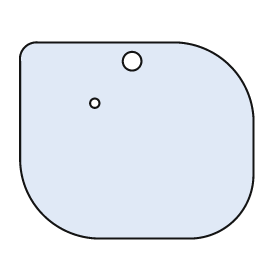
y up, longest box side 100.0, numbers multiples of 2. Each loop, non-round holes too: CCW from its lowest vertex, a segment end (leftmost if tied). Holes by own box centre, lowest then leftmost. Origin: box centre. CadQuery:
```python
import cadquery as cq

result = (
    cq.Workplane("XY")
    .moveTo(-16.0, -42.0)
    .lineTo(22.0, -42.0)
    .threePointArc((42.0, -34.0), (50.0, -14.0))
    .lineTo(50.0, 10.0)
    .threePointArc((40.0, 32.0), (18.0, 42.0))
    .lineTo(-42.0, 42.0)
    .threePointArc((-48.0, 40.0), (-50.0, 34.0))
    .lineTo(-50.0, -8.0)
    .threePointArc((-40.0, -32.0), (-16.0, -42.0))
    .close()
    .moveTo(-18.0, 16.0)
    .circle(2.0)
    .moveTo(-2.0, 34.0)
    .circle(4.0)
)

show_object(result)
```